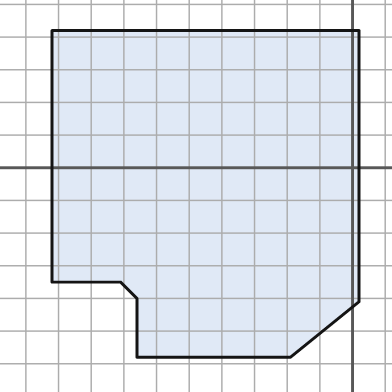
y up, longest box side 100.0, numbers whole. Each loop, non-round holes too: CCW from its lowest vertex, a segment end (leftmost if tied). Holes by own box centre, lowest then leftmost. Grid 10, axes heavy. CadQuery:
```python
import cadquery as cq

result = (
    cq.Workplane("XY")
    .moveTo(-66.0, -58.0)
    .lineTo(-19.0, -58.0)
    .lineTo(2.0, -41.0)
    .lineTo(2.0, 42.0)
    .lineTo(-92.0, 42.0)
    .lineTo(-92.0, -35.0)
    .lineTo(-71.0, -35.0)
    .lineTo(-66.0, -40.0)
    .close()
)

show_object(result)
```